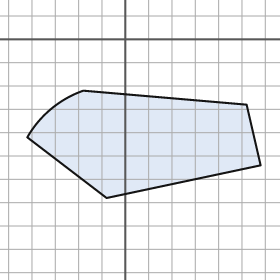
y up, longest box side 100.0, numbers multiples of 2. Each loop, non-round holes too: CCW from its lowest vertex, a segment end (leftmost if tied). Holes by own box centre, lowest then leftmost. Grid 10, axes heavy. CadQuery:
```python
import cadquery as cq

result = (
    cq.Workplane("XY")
    .moveTo(-8.0, -68.0)
    .lineTo(58.0, -54.0)
    .lineTo(52.0, -28.0)
    .lineTo(-18.0, -22.0)
    .threePointArc((-32.0, -30.0), (-42.0, -42.0))
    .close()
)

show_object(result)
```